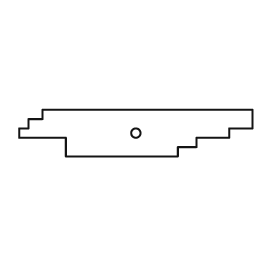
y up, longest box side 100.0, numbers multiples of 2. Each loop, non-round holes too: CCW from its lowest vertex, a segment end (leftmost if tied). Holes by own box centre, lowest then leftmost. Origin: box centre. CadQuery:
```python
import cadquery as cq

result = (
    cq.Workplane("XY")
    .moveTo(-30.0, -10.0)
    .lineTo(18.0, -10.0)
    .lineTo(18.0, -6.0)
    .lineTo(26.0, -6.0)
    .lineTo(26.0, -2.0)
    .lineTo(40.0, -2.0)
    .lineTo(40.0, 2.0)
    .lineTo(50.0, 2.0)
    .lineTo(50.0, 10.0)
    .lineTo(-40.0, 10.0)
    .lineTo(-40.0, 6.0)
    .lineTo(-46.0, 6.0)
    .lineTo(-46.0, 2.0)
    .lineTo(-50.0, 2.0)
    .lineTo(-50.0, -2.0)
    .lineTo(-30.0, -2.0)
    .close()
    .moveTo(0.0, 0.0)
    .circle(2.0)
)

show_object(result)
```